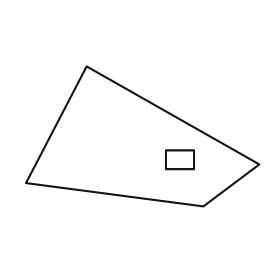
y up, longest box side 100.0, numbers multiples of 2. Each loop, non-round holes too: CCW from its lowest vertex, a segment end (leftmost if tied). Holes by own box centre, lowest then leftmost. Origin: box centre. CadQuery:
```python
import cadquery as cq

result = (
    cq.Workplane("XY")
    .moveTo(26.0, -30.0)
    .lineTo(50.0, -12.0)
    .lineTo(-24.0, 30.0)
    .lineTo(-50.0, -20.0)
    .close()
    .moveTo(10.0, -14.0)
    .lineTo(22.0, -14.0)
    .lineTo(22.0, -6.0)
    .lineTo(10.0, -6.0)
    .close()
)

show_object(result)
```